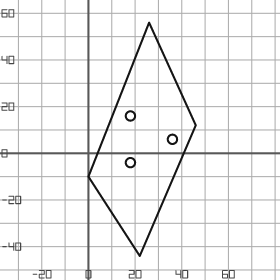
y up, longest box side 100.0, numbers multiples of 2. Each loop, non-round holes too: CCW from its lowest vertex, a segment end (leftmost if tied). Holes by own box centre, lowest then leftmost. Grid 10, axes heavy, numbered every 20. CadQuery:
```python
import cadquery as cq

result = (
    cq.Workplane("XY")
    .moveTo(22.0, -44.0)
    .lineTo(46.0, 12.0)
    .lineTo(26.0, 56.0)
    .lineTo(0.0, -10.0)
    .close()
    .moveTo(18.0, -4.0)
    .circle(2.0)
    .moveTo(36.0, 6.0)
    .circle(2.0)
    .moveTo(18.0, 16.0)
    .circle(2.0)
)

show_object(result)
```